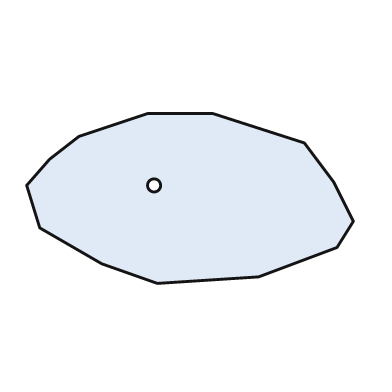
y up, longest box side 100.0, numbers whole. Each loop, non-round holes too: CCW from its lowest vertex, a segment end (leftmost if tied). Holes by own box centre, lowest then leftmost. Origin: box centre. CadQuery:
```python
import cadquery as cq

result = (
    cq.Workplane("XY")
    .moveTo(-10.0, -26.0)
    .lineTo(21.0, -24.0)
    .lineTo(45.0, -15.0)
    .lineTo(50.0, -7.0)
    .lineTo(44.0, 5.0)
    .lineTo(35.0, 17.0)
    .lineTo(7.0, 26.0)
    .lineTo(-13.0, 26.0)
    .lineTo(-34.0, 19.0)
    .lineTo(-43.0, 12.0)
    .lineTo(-50.0, 4.0)
    .lineTo(-46.0, -9.0)
    .lineTo(-27.0, -20.0)
    .close()
    .moveTo(-11.0, 4.0)
    .circle(2.0)
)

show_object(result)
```